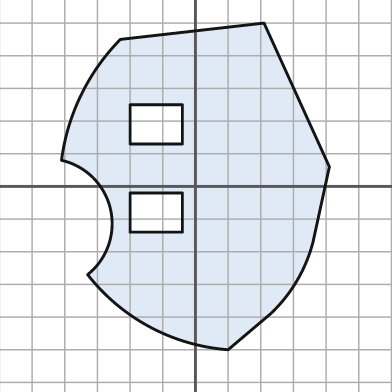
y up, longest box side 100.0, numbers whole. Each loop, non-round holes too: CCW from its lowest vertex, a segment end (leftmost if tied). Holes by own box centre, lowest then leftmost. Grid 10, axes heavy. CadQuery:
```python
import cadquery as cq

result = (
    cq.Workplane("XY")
    .moveTo(10.0, -50.0)
    .lineTo(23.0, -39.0)
    .threePointArc((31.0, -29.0), (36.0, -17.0))
    .lineTo(41.0, 6.0)
    .lineTo(21.0, 50.0)
    .lineTo(-23.0, 45.0)
    .threePointArc((-35.0, 28.0), (-41.0, 8.0))
    .threePointArc((-26.0, -7.0), (-33.0, -27.0))
    .threePointArc((-14.0, -43.0), (10.0, -50.0))
    .close()
    .moveTo(-20.0, -14.0)
    .lineTo(-4.0, -14.0)
    .lineTo(-4.0, -2.0)
    .lineTo(-20.0, -2.0)
    .close()
    .moveTo(-20.0, 13.0)
    .lineTo(-4.0, 13.0)
    .lineTo(-4.0, 25.0)
    .lineTo(-20.0, 25.0)
    .close()
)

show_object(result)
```